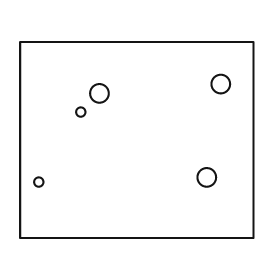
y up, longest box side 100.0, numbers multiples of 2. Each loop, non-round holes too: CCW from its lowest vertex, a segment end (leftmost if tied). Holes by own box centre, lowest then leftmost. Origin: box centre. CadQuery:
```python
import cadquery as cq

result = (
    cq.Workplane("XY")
    .moveTo(-50.0, -42.0)
    .lineTo(50.0, -42.0)
    .lineTo(50.0, 42.0)
    .lineTo(-50.0, 42.0)
    .close()
    .moveTo(-42.0, -18.0)
    .circle(2.0)
    .moveTo(30.0, -16.0)
    .circle(4.0)
    .moveTo(-24.0, 12.0)
    .circle(2.0)
    .moveTo(-16.0, 20.0)
    .circle(4.0)
    .moveTo(36.0, 24.0)
    .circle(4.0)
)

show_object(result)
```